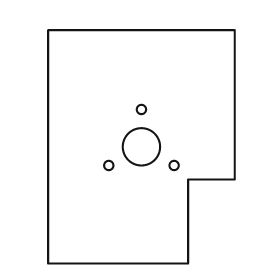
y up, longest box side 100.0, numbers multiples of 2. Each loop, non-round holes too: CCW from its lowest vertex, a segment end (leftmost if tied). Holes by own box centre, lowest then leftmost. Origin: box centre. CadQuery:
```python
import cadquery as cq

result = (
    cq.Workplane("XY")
    .moveTo(-40.0, -50.0)
    .lineTo(20.0, -50.0)
    .lineTo(20.0, -14.0)
    .lineTo(40.0, -14.0)
    .lineTo(40.0, 50.0)
    .lineTo(-40.0, 50.0)
    .close()
    .moveTo(-14.0, -8.0)
    .circle(2.0)
    .moveTo(14.0, -8.0)
    .circle(2.0)
    .moveTo(0.0, 0.0)
    .circle(8.0)
    .moveTo(0.0, 16.0)
    .circle(2.0)
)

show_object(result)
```